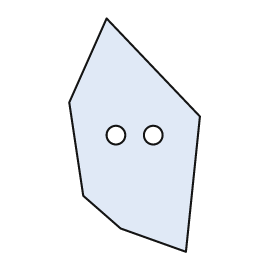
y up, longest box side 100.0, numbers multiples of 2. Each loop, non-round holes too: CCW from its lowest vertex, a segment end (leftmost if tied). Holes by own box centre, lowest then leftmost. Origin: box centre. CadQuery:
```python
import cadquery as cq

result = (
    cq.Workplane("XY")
    .moveTo(22.0, -50.0)
    .lineTo(28.0, 8.0)
    .lineTo(-12.0, 50.0)
    .lineTo(-28.0, 14.0)
    .lineTo(-22.0, -26.0)
    .lineTo(-6.0, -40.0)
    .close()
    .moveTo(-8.0, 0.0)
    .circle(4.0)
    .moveTo(8.0, 0.0)
    .circle(4.0)
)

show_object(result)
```